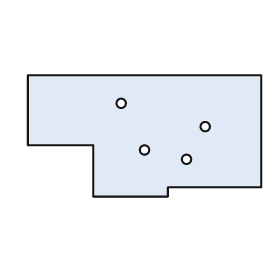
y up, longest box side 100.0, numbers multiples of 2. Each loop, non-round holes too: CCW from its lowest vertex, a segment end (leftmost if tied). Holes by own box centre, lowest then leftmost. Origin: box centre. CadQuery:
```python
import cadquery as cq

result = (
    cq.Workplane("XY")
    .moveTo(-22.0, -26.0)
    .lineTo(10.0, -26.0)
    .lineTo(10.0, -22.0)
    .lineTo(50.0, -22.0)
    .lineTo(50.0, 26.0)
    .lineTo(-50.0, 26.0)
    .lineTo(-50.0, -4.0)
    .lineTo(-22.0, -4.0)
    .close()
    .moveTo(18.0, -10.0)
    .circle(2.0)
    .moveTo(0.0, -6.0)
    .circle(2.0)
    .moveTo(26.0, 4.0)
    .circle(2.0)
    .moveTo(-10.0, 14.0)
    .circle(2.0)
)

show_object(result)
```